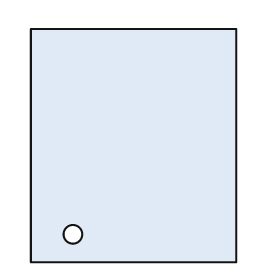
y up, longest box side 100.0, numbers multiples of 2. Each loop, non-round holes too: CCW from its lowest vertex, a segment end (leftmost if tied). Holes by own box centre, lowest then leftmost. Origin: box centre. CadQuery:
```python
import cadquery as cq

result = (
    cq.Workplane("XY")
    .moveTo(-44.0, -50.0)
    .lineTo(44.0, -50.0)
    .lineTo(44.0, 50.0)
    .lineTo(-44.0, 50.0)
    .close()
    .moveTo(-26.0, -38.0)
    .circle(4.0)
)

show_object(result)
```